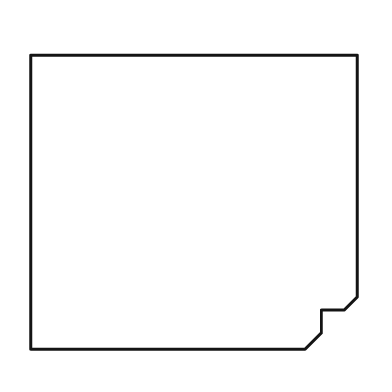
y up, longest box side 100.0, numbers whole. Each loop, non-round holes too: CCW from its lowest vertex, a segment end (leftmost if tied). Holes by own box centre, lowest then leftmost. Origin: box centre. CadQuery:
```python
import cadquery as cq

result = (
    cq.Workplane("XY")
    .moveTo(-50.0, -45.0)
    .lineTo(34.0, -45.0)
    .lineTo(39.0, -40.0)
    .lineTo(39.0, -33.0)
    .lineTo(46.0, -33.0)
    .lineTo(50.0, -29.0)
    .lineTo(50.0, 45.0)
    .lineTo(-50.0, 45.0)
    .close()
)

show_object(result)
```